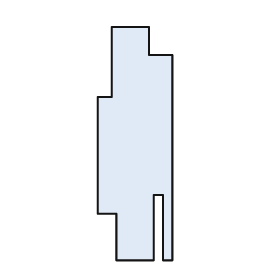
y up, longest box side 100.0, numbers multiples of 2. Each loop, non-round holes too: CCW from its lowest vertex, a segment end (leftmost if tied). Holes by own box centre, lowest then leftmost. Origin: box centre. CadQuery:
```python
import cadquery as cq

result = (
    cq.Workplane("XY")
    .moveTo(-8.0, -50.0)
    .lineTo(8.0, -50.0)
    .lineTo(8.0, -22.0)
    .lineTo(12.0, -22.0)
    .lineTo(12.0, -50.0)
    .lineTo(16.0, -50.0)
    .lineTo(16.0, 38.0)
    .lineTo(6.0, 38.0)
    .lineTo(6.0, 50.0)
    .lineTo(-10.0, 50.0)
    .lineTo(-10.0, 20.0)
    .lineTo(-16.0, 20.0)
    .lineTo(-16.0, -30.0)
    .lineTo(-8.0, -30.0)
    .close()
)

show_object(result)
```